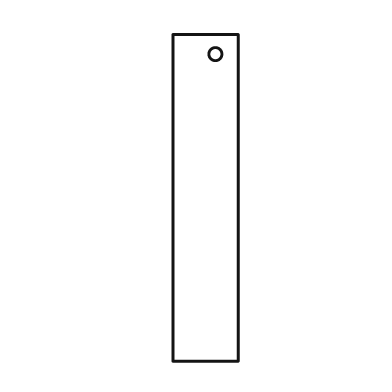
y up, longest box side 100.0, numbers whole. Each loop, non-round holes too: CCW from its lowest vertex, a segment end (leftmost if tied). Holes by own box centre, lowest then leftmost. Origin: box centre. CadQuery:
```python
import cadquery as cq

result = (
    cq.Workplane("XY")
    .moveTo(-10.0, -50.0)
    .lineTo(10.0, -50.0)
    .lineTo(10.0, 50.0)
    .lineTo(-10.0, 50.0)
    .close()
    .moveTo(3.0, 44.0)
    .circle(2.0)
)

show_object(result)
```